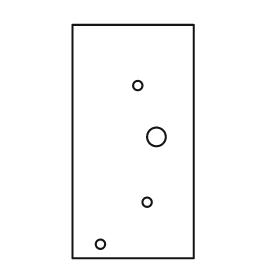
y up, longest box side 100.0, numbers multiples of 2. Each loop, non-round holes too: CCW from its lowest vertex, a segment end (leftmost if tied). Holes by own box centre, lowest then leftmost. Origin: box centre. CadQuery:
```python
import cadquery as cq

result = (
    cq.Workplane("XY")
    .moveTo(-26.0, -50.0)
    .lineTo(26.0, -50.0)
    .lineTo(26.0, 50.0)
    .lineTo(-26.0, 50.0)
    .close()
    .moveTo(-14.0, -44.0)
    .circle(2.0)
    .moveTo(6.0, -26.0)
    .circle(2.0)
    .moveTo(10.0, 2.0)
    .circle(4.0)
    .moveTo(2.0, 24.0)
    .circle(2.0)
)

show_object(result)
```